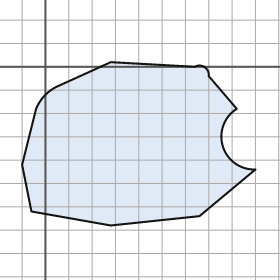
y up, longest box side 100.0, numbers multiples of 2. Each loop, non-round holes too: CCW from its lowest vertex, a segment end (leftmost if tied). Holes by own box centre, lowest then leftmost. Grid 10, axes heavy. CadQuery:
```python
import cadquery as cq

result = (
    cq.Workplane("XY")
    .moveTo(28.0, -68.0)
    .lineTo(66.0, -64.0)
    .lineTo(90.0, -44.0)
    .threePointArc((76.0, -34.0), (82.0, -18.0))
    .lineTo(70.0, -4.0)
    .threePointArc((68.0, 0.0), (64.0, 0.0))
    .lineTo(28.0, 2.0)
    .lineTo(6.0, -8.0)
    .threePointArc((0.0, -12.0), (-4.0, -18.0))
    .lineTo(-10.0, -42.0)
    .lineTo(-6.0, -62.0)
    .close()
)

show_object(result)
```